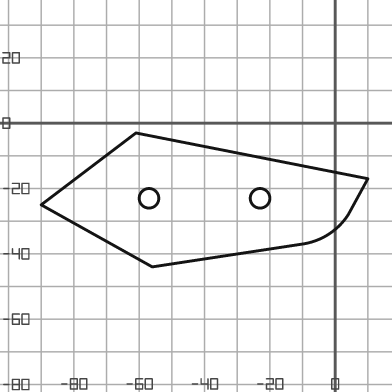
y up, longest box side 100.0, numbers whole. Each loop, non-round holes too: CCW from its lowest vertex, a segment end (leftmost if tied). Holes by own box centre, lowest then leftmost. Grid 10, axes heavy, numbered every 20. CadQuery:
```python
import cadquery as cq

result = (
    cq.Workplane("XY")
    .moveTo(-56.0, -44.0)
    .lineTo(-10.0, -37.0)
    .threePointArc((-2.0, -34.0), (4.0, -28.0))
    .lineTo(10.0, -17.0)
    .lineTo(-61.0, -3.0)
    .lineTo(-90.0, -25.0)
    .close()
    .moveTo(-57.0, -23.0)
    .circle(3.0)
    .moveTo(-23.0, -23.0)
    .circle(3.0)
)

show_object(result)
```